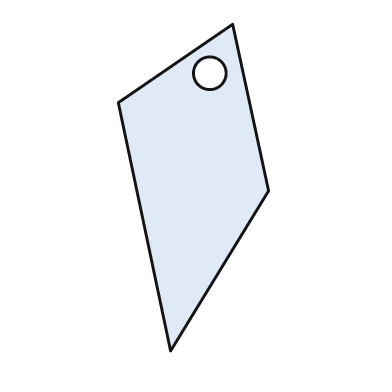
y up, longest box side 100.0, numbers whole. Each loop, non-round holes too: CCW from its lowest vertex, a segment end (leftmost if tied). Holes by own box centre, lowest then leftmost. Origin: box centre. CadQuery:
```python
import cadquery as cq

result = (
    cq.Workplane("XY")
    .moveTo(-7.0, -50.0)
    .lineTo(23.0, -1.0)
    .lineTo(12.0, 50.0)
    .lineTo(-23.0, 26.0)
    .close()
    .moveTo(5.0, 35.0)
    .circle(5.0)
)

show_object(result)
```